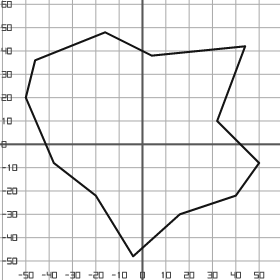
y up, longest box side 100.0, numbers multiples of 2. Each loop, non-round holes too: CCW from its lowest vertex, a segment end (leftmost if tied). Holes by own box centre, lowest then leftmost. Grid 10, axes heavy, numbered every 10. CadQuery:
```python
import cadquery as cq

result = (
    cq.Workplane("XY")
    .moveTo(-4.0, -48.0)
    .lineTo(16.0, -30.0)
    .lineTo(40.0, -22.0)
    .lineTo(50.0, -8.0)
    .lineTo(32.0, 10.0)
    .lineTo(44.0, 42.0)
    .lineTo(4.0, 38.0)
    .lineTo(-16.0, 48.0)
    .lineTo(-46.0, 36.0)
    .lineTo(-50.0, 20.0)
    .lineTo(-38.0, -8.0)
    .lineTo(-20.0, -22.0)
    .close()
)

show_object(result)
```